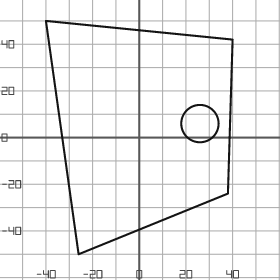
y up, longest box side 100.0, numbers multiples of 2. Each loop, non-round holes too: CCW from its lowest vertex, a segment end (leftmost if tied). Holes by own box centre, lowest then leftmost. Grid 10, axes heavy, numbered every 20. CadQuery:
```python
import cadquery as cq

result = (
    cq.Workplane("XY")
    .moveTo(-26.0, -50.0)
    .lineTo(38.0, -24.0)
    .lineTo(40.0, 42.0)
    .lineTo(-40.0, 50.0)
    .close()
    .moveTo(26.0, 6.0)
    .circle(8.0)
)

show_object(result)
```